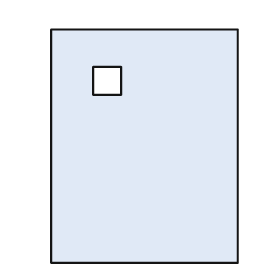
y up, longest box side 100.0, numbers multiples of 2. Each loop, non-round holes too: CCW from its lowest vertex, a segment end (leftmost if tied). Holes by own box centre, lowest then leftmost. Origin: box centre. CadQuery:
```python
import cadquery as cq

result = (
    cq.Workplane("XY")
    .moveTo(-40.0, -50.0)
    .lineTo(40.0, -50.0)
    .lineTo(40.0, 50.0)
    .lineTo(-40.0, 50.0)
    .close()
    .moveTo(-22.0, 22.0)
    .lineTo(-10.0, 22.0)
    .lineTo(-10.0, 34.0)
    .lineTo(-22.0, 34.0)
    .close()
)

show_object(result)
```